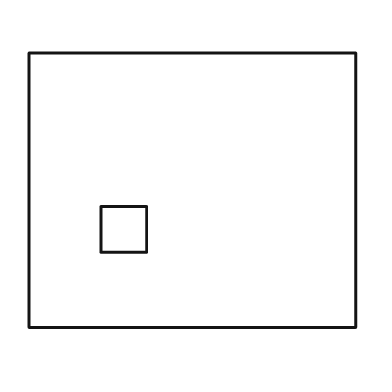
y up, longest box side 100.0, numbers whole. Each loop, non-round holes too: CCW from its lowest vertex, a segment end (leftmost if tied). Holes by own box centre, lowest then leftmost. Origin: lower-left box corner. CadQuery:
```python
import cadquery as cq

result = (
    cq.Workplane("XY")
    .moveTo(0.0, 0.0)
    .lineTo(100.0, 0.0)
    .lineTo(100.0, 84.0)
    .lineTo(0.0, 84.0)
    .close()
    .moveTo(22.0, 23.0)
    .lineTo(36.0, 23.0)
    .lineTo(36.0, 37.0)
    .lineTo(22.0, 37.0)
    .close()
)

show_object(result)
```